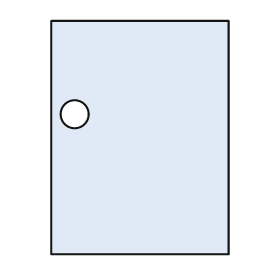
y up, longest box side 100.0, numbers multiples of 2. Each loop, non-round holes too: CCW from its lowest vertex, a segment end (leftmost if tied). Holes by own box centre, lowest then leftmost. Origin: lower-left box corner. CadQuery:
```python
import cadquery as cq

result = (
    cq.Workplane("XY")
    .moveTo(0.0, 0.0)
    .lineTo(76.0, 0.0)
    .lineTo(76.0, 100.0)
    .lineTo(0.0, 100.0)
    .close()
    .moveTo(10.0, 60.0)
    .circle(6.0)
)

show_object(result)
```